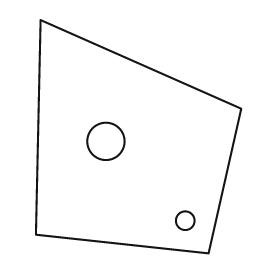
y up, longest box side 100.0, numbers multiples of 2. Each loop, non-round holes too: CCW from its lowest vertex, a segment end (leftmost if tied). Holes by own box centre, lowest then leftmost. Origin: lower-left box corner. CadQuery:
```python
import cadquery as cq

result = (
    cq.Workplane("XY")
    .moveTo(74.0, 0.0)
    .lineTo(88.0, 62.0)
    .lineTo(2.0, 100.0)
    .lineTo(0.0, 8.0)
    .close()
    .moveTo(64.0, 14.0)
    .circle(4.0)
    .moveTo(30.0, 48.0)
    .circle(8.0)
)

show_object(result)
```